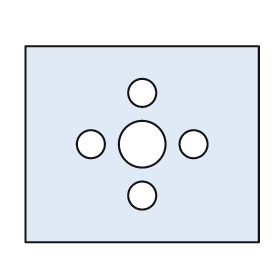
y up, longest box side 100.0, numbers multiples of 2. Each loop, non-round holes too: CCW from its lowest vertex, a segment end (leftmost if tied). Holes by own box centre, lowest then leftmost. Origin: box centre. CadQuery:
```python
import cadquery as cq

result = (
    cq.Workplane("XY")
    .moveTo(-50.0, -42.0)
    .lineTo(50.0, -42.0)
    .lineTo(50.0, 42.0)
    .lineTo(-50.0, 42.0)
    .close()
    .moveTo(0.0, -22.0)
    .circle(6.0)
    .moveTo(-22.0, 0.0)
    .circle(6.0)
    .moveTo(0.0, 0.0)
    .circle(10.0)
    .moveTo(22.0, 0.0)
    .circle(6.0)
    .moveTo(0.0, 22.0)
    .circle(6.0)
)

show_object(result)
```